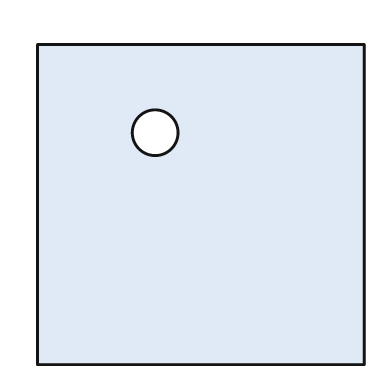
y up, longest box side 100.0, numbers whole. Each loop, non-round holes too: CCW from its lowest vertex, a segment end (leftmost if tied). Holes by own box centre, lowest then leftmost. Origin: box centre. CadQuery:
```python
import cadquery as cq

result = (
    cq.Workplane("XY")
    .moveTo(-50.0, -49.0)
    .lineTo(50.0, -49.0)
    .lineTo(50.0, 49.0)
    .lineTo(-50.0, 49.0)
    .close()
    .moveTo(-14.0, 22.0)
    .circle(7.0)
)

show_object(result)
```